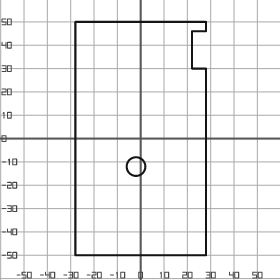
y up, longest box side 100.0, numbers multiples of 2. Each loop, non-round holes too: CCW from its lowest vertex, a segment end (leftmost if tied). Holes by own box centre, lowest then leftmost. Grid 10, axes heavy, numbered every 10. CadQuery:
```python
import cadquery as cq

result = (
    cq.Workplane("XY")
    .moveTo(-28.0, -50.0)
    .lineTo(28.0, -50.0)
    .lineTo(28.0, 30.0)
    .lineTo(22.0, 30.0)
    .lineTo(22.0, 46.0)
    .lineTo(28.0, 46.0)
    .lineTo(28.0, 50.0)
    .lineTo(-28.0, 50.0)
    .close()
    .moveTo(-2.0, -12.0)
    .circle(4.0)
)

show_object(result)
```